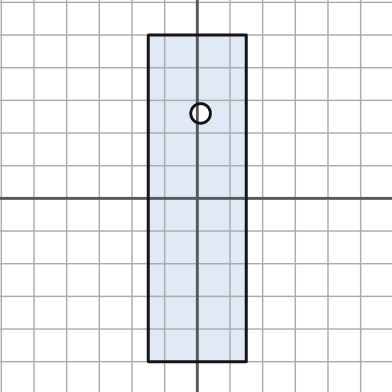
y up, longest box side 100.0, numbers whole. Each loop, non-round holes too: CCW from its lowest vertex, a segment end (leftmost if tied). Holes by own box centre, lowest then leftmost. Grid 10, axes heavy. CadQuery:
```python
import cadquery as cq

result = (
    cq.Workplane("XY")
    .moveTo(-15.0, -50.0)
    .lineTo(15.0, -50.0)
    .lineTo(15.0, 50.0)
    .lineTo(-15.0, 50.0)
    .close()
    .moveTo(1.0, 26.0)
    .circle(3.0)
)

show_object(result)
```